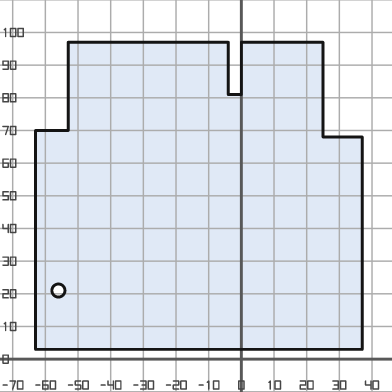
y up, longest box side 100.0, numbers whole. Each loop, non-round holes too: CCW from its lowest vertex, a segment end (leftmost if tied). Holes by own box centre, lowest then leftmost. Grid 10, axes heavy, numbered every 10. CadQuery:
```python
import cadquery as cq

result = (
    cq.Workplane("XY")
    .moveTo(-63.0, 3.0)
    .lineTo(37.0, 3.0)
    .lineTo(37.0, 68.0)
    .lineTo(25.0, 68.0)
    .lineTo(25.0, 97.0)
    .lineTo(0.0, 97.0)
    .lineTo(0.0, 81.0)
    .lineTo(-4.0, 81.0)
    .lineTo(-4.0, 97.0)
    .lineTo(-53.0, 97.0)
    .lineTo(-53.0, 70.0)
    .lineTo(-63.0, 70.0)
    .close()
    .moveTo(-56.0, 21.0)
    .circle(2.0)
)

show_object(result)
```